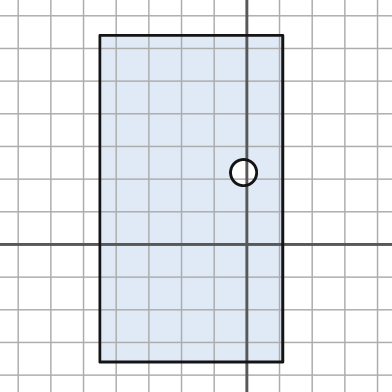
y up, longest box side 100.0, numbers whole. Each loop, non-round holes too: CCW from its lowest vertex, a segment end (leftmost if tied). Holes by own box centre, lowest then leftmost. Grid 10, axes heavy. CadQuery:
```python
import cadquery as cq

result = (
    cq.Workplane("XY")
    .moveTo(-45.0, -36.0)
    .lineTo(11.0, -36.0)
    .lineTo(11.0, 64.0)
    .lineTo(-45.0, 64.0)
    .close()
    .moveTo(-1.0, 22.0)
    .circle(4.0)
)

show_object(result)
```